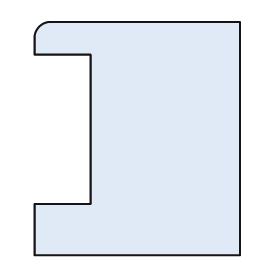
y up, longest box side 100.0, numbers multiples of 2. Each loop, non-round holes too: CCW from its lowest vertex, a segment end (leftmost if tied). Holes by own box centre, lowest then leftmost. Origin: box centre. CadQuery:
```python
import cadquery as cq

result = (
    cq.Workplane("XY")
    .moveTo(-44.0, -50.0)
    .lineTo(44.0, -50.0)
    .lineTo(44.0, 50.0)
    .lineTo(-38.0, 50.0)
    .threePointArc((-42.0, 48.0), (-44.0, 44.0))
    .lineTo(-44.0, 36.0)
    .lineTo(-20.0, 36.0)
    .lineTo(-20.0, -28.0)
    .lineTo(-44.0, -28.0)
    .close()
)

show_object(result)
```